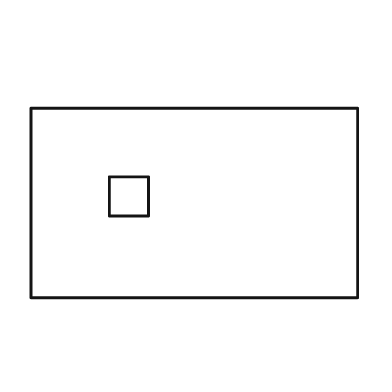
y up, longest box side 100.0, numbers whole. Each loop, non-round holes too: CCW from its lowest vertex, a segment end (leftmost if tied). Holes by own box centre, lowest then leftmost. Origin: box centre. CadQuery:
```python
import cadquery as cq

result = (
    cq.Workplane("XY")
    .moveTo(-50.0, -29.0)
    .lineTo(50.0, -29.0)
    .lineTo(50.0, 29.0)
    .lineTo(-50.0, 29.0)
    .close()
    .moveTo(-26.0, -4.0)
    .lineTo(-14.0, -4.0)
    .lineTo(-14.0, 8.0)
    .lineTo(-26.0, 8.0)
    .close()
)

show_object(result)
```